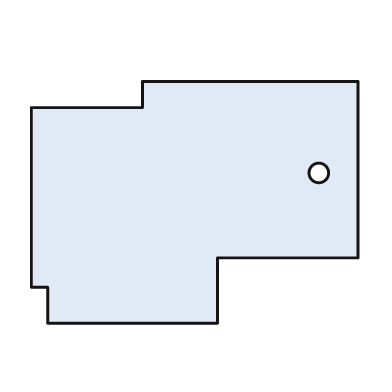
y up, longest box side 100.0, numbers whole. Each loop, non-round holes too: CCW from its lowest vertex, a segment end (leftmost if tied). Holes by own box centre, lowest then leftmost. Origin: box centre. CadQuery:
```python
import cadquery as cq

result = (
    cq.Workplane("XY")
    .moveTo(-45.0, -37.0)
    .lineTo(7.0, -37.0)
    .lineTo(7.0, -17.0)
    .lineTo(50.0, -17.0)
    .lineTo(50.0, 37.0)
    .lineTo(-16.0, 37.0)
    .lineTo(-16.0, 29.0)
    .lineTo(-50.0, 29.0)
    .lineTo(-50.0, -26.0)
    .lineTo(-45.0, -26.0)
    .close()
    .moveTo(38.0, 9.0)
    .circle(3.0)
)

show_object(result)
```